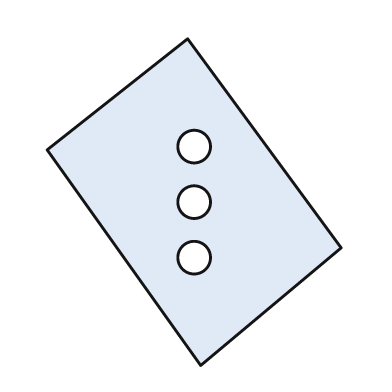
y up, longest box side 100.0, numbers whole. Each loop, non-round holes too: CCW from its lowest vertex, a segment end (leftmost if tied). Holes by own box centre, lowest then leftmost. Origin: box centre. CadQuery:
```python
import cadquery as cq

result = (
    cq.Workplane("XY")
    .moveTo(2.0, -50.0)
    .lineTo(45.0, -14.0)
    .lineTo(-2.0, 50.0)
    .lineTo(-45.0, 16.0)
    .close()
    .moveTo(0.0, -17.0)
    .circle(5.0)
    .moveTo(0.0, 0.0)
    .circle(5.0)
    .moveTo(0.0, 17.0)
    .circle(5.0)
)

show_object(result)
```